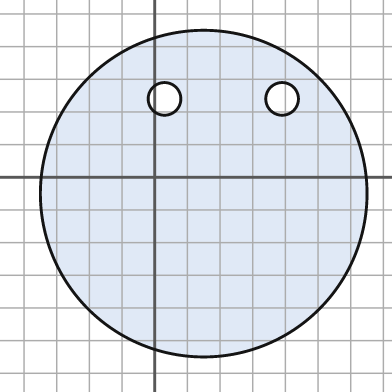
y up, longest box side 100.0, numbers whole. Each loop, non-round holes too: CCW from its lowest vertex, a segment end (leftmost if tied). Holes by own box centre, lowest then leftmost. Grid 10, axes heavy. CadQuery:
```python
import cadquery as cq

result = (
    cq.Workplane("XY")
    .moveTo(15.0, -5.0)
    .circle(50.0)
    .moveTo(3.0, 24.0)
    .circle(5.0)
    .moveTo(39.0, 24.0)
    .circle(5.0)
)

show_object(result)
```